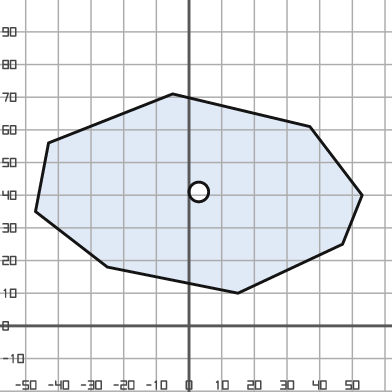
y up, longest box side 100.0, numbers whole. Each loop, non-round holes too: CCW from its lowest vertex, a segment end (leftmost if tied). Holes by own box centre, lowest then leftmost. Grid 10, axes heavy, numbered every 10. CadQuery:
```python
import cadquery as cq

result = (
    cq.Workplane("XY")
    .moveTo(15.0, 10.0)
    .lineTo(47.0, 25.0)
    .lineTo(53.0, 40.0)
    .lineTo(37.0, 61.0)
    .lineTo(-5.0, 71.0)
    .lineTo(-43.0, 56.0)
    .lineTo(-47.0, 35.0)
    .lineTo(-25.0, 18.0)
    .close()
    .moveTo(3.0, 41.0)
    .circle(3.0)
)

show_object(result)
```